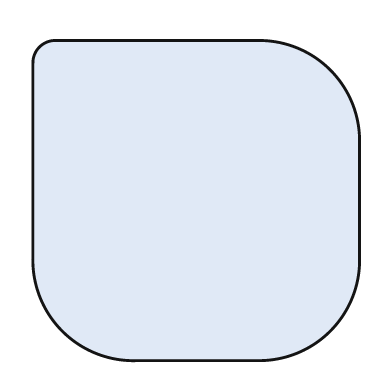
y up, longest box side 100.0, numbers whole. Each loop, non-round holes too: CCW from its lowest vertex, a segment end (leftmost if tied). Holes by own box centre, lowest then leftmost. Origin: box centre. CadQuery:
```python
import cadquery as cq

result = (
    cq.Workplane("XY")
    .moveTo(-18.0, -49.0)
    .lineTo(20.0, -49.0)
    .threePointArc((41.0, -40.0), (50.0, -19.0))
    .lineTo(50.0, 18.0)
    .threePointArc((41.0, 40.0), (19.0, 49.0))
    .lineTo(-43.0, 49.0)
    .threePointArc((-48.0, 47.0), (-50.0, 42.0))
    .lineTo(-50.0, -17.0)
    .threePointArc((-41.0, -40.0), (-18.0, -49.0))
    .close()
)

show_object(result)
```